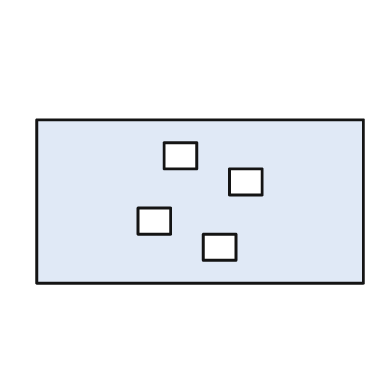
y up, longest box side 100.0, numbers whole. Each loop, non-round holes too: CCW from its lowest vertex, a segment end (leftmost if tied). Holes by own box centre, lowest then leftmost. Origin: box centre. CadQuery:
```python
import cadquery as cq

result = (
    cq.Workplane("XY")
    .moveTo(-50.0, -25.0)
    .lineTo(50.0, -25.0)
    .lineTo(50.0, 25.0)
    .lineTo(-50.0, 25.0)
    .close()
    .moveTo(1.0, -18.0)
    .lineTo(11.0, -18.0)
    .lineTo(11.0, -10.0)
    .lineTo(1.0, -10.0)
    .close()
    .moveTo(-19.0, -10.0)
    .lineTo(-9.0, -10.0)
    .lineTo(-9.0, -2.0)
    .lineTo(-19.0, -2.0)
    .close()
    .moveTo(9.0, 2.0)
    .lineTo(19.0, 2.0)
    .lineTo(19.0, 10.0)
    .lineTo(9.0, 10.0)
    .close()
    .moveTo(-11.0, 10.0)
    .lineTo(-1.0, 10.0)
    .lineTo(-1.0, 18.0)
    .lineTo(-11.0, 18.0)
    .close()
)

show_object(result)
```